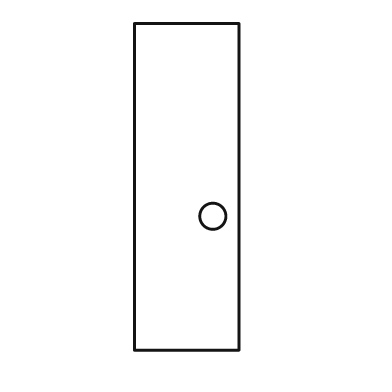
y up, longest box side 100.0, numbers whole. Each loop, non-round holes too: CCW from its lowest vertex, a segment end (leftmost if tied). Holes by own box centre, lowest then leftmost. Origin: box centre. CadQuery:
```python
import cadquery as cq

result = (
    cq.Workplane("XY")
    .moveTo(-16.0, -50.0)
    .lineTo(16.0, -50.0)
    .lineTo(16.0, 50.0)
    .lineTo(-16.0, 50.0)
    .close()
    .moveTo(8.0, -9.0)
    .circle(4.0)
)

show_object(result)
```